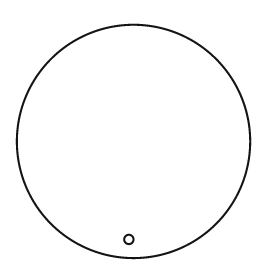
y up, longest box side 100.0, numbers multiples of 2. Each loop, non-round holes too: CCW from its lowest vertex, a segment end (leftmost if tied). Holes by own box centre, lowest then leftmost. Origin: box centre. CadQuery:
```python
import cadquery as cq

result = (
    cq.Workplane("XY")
    .moveTo(0.0, 0.0)
    .circle(50.0)
    .moveTo(-2.0, -42.0)
    .circle(2.0)
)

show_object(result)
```